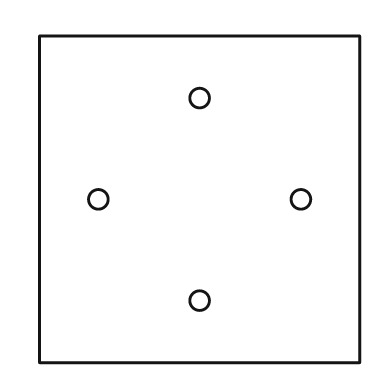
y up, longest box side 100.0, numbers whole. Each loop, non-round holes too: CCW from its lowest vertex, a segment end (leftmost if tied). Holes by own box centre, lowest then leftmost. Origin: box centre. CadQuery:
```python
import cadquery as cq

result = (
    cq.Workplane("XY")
    .moveTo(-49.0, -50.0)
    .lineTo(49.0, -50.0)
    .lineTo(49.0, 50.0)
    .lineTo(-49.0, 50.0)
    .close()
    .moveTo(0.0, -31.0)
    .circle(3.0)
    .moveTo(-31.0, 0.0)
    .circle(3.0)
    .moveTo(31.0, 0.0)
    .circle(3.0)
    .moveTo(0.0, 31.0)
    .circle(3.0)
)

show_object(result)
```